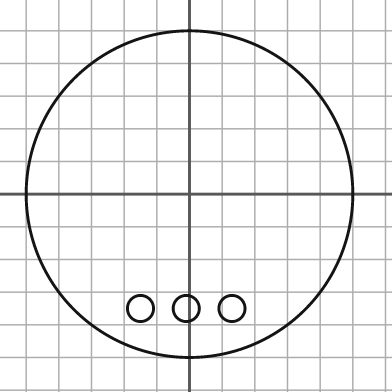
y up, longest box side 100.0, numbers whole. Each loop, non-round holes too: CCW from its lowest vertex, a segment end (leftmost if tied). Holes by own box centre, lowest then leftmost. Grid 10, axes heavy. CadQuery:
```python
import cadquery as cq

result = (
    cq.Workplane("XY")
    .moveTo(0.0, 0.0)
    .circle(50.0)
    .moveTo(-15.0, -35.0)
    .circle(4.0)
    .moveTo(-1.0, -35.0)
    .circle(4.0)
    .moveTo(13.0, -35.0)
    .circle(4.0)
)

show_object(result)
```